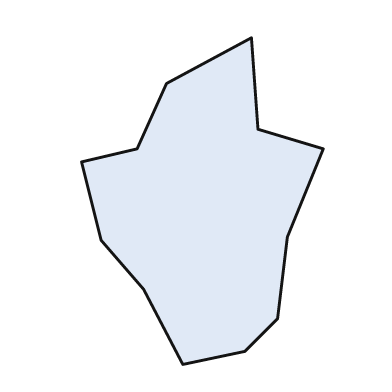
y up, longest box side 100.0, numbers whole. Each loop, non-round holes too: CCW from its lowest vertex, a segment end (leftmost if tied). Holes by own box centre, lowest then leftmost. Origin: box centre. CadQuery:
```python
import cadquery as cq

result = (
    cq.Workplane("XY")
    .moveTo(-6.0, -50.0)
    .lineTo(13.0, -46.0)
    .lineTo(23.0, -36.0)
    .lineTo(26.0, -11.0)
    .lineTo(37.0, 16.0)
    .lineTo(17.0, 22.0)
    .lineTo(15.0, 50.0)
    .lineTo(-11.0, 36.0)
    .lineTo(-20.0, 16.0)
    .lineTo(-37.0, 12.0)
    .lineTo(-31.0, -12.0)
    .lineTo(-18.0, -27.0)
    .close()
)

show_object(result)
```